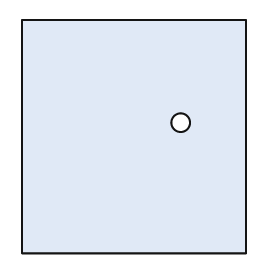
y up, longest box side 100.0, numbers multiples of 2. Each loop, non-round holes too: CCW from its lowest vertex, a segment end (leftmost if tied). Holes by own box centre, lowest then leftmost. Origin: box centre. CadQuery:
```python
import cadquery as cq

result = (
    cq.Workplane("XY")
    .moveTo(-48.0, -50.0)
    .lineTo(48.0, -50.0)
    .lineTo(48.0, 50.0)
    .lineTo(-48.0, 50.0)
    .close()
    .moveTo(20.0, 6.0)
    .circle(4.0)
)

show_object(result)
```